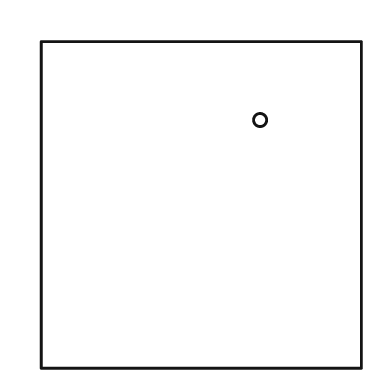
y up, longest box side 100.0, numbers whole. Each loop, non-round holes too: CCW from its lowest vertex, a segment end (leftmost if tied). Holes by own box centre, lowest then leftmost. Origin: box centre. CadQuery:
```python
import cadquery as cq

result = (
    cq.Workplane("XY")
    .moveTo(-49.0, -50.0)
    .lineTo(49.0, -50.0)
    .lineTo(49.0, 50.0)
    .lineTo(-49.0, 50.0)
    .close()
    .moveTo(18.0, 26.0)
    .circle(2.0)
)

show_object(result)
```